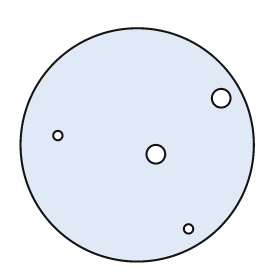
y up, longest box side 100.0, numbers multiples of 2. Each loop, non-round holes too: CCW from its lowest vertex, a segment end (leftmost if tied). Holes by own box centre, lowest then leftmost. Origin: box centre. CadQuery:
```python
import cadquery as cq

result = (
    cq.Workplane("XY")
    .moveTo(0.0, 0.0)
    .circle(50.0)
    .moveTo(22.0, -36.0)
    .circle(2.0)
    .moveTo(8.0, -4.0)
    .circle(4.0)
    .moveTo(-34.0, 4.0)
    .circle(2.0)
    .moveTo(36.0, 20.0)
    .circle(4.0)
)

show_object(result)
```